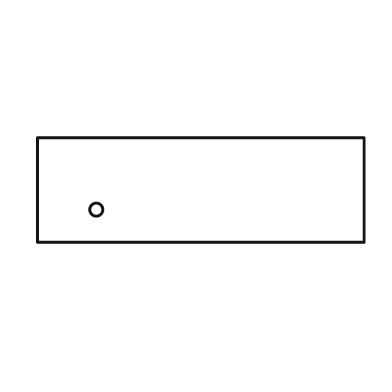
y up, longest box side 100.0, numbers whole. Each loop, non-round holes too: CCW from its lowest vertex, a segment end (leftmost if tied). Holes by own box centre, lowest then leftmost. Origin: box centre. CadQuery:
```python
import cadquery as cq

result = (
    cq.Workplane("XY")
    .moveTo(-50.0, -16.0)
    .lineTo(50.0, -16.0)
    .lineTo(50.0, 16.0)
    .lineTo(-50.0, 16.0)
    .close()
    .moveTo(-32.0, -6.0)
    .circle(2.0)
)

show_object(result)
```